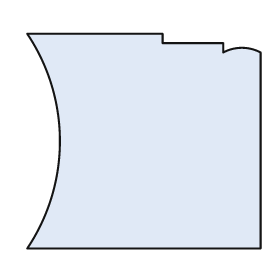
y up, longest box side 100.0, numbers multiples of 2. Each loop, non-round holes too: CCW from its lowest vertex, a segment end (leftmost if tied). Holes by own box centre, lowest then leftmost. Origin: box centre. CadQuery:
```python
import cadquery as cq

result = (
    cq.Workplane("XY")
    .moveTo(-50.0, -46.0)
    .lineTo(50.0, -46.0)
    .lineTo(50.0, 38.0)
    .threePointArc((42.0, 40.0), (34.0, 38.0))
    .lineTo(34.0, 42.0)
    .lineTo(8.0, 42.0)
    .lineTo(8.0, 46.0)
    .lineTo(-50.0, 46.0)
    .threePointArc((-36.0, 0.0), (-50.0, -46.0))
    .close()
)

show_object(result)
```